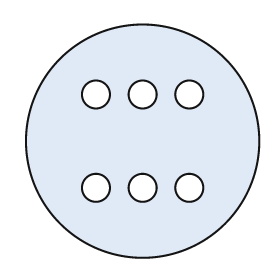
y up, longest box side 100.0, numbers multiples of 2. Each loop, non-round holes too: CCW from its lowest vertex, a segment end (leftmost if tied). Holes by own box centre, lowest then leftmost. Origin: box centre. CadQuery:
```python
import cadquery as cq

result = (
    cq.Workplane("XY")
    .moveTo(0.0, 0.0)
    .circle(50.0)
    .moveTo(-20.0, -20.0)
    .circle(6.0)
    .moveTo(0.0, -20.0)
    .circle(6.0)
    .moveTo(20.0, -20.0)
    .circle(6.0)
    .moveTo(-20.0, 20.0)
    .circle(6.0)
    .moveTo(0.0, 20.0)
    .circle(6.0)
    .moveTo(20.0, 20.0)
    .circle(6.0)
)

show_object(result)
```